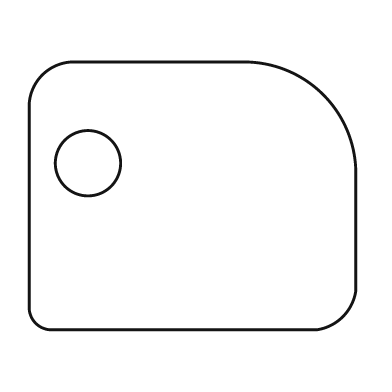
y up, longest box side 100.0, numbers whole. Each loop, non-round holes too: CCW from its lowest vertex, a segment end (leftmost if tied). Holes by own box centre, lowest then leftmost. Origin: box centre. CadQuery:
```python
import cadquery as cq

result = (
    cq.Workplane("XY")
    .moveTo(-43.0, -41.0)
    .lineTo(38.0, -41.0)
    .threePointArc((46.0, -37.0), (50.0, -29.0))
    .lineTo(50.0, 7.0)
    .threePointArc((40.0, 31.0), (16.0, 41.0))
    .lineTo(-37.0, 41.0)
    .threePointArc((-46.0, 37.0), (-50.0, 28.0))
    .lineTo(-50.0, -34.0)
    .threePointArc((-48.0, -39.0), (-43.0, -41.0))
    .close()
    .moveTo(-32.0, 10.0)
    .circle(10.0)
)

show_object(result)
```